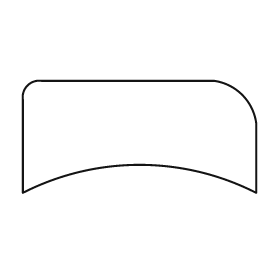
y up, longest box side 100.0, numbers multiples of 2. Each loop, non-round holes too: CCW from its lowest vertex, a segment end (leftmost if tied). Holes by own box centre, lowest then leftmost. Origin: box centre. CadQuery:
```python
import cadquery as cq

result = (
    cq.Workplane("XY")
    .moveTo(-50.0, -24.0)
    .threePointArc((0.0, -12.0), (50.0, -24.0))
    .lineTo(50.0, 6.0)
    .threePointArc((44.0, 18.0), (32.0, 24.0))
    .lineTo(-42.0, 24.0)
    .threePointArc((-48.0, 22.0), (-50.0, 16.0))
    .close()
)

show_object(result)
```